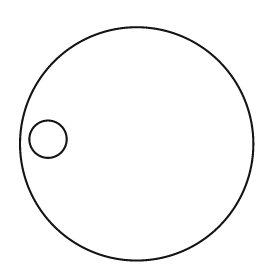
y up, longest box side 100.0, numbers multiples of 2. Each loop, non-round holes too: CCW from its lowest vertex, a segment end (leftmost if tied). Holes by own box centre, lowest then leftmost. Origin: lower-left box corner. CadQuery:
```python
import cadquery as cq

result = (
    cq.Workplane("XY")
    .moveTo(50.0, 50.0)
    .circle(50.0)
    .moveTo(12.0, 52.0)
    .circle(8.0)
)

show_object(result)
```